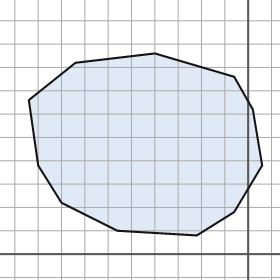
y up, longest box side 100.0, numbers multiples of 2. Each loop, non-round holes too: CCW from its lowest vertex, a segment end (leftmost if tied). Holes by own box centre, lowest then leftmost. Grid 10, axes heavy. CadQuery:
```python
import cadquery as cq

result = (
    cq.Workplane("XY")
    .moveTo(-22.0, 8.0)
    .lineTo(-6.0, 18.0)
    .lineTo(6.0, 38.0)
    .lineTo(2.0, 62.0)
    .lineTo(-6.0, 76.0)
    .lineTo(-40.0, 86.0)
    .lineTo(-74.0, 82.0)
    .lineTo(-94.0, 66.0)
    .lineTo(-90.0, 38.0)
    .lineTo(-80.0, 22.0)
    .lineTo(-56.0, 10.0)
    .close()
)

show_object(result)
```